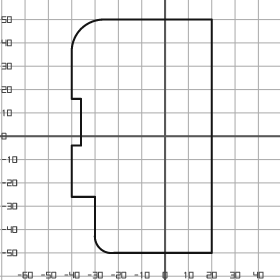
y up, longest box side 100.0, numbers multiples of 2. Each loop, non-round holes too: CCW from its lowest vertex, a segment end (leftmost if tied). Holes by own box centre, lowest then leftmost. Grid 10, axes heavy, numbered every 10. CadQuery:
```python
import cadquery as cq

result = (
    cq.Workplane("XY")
    .moveTo(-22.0, -50.0)
    .lineTo(20.0, -50.0)
    .lineTo(20.0, 50.0)
    .lineTo(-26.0, 50.0)
    .threePointArc((-36.0, 46.0), (-40.0, 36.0))
    .lineTo(-40.0, 16.0)
    .lineTo(-36.0, 16.0)
    .lineTo(-36.0, -4.0)
    .lineTo(-40.0, -4.0)
    .lineTo(-40.0, -26.0)
    .lineTo(-30.0, -26.0)
    .lineTo(-30.0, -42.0)
    .threePointArc((-28.0, -48.0), (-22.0, -50.0))
    .close()
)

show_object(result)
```